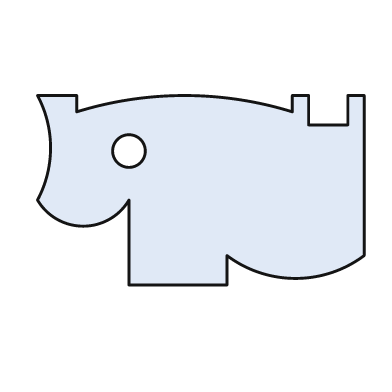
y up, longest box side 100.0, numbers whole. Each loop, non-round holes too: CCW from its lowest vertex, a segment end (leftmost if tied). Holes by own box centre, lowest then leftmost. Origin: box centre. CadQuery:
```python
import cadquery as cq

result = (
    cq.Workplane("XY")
    .moveTo(-22.0, -29.0)
    .lineTo(8.0, -29.0)
    .lineTo(8.0, -20.0)
    .threePointArc((29.0, -27.0), (50.0, -20.0))
    .lineTo(50.0, 29.0)
    .lineTo(45.0, 29.0)
    .lineTo(45.0, 20.0)
    .lineTo(33.0, 20.0)
    .lineTo(33.0, 29.0)
    .lineTo(28.0, 29.0)
    .lineTo(28.0, 24.0)
    .threePointArc((-5.0, 29.0), (-38.0, 24.0))
    .lineTo(-38.0, 29.0)
    .lineTo(-50.0, 29.0)
    .threePointArc((-46.0, 13.0), (-50.0, -3.0))
    .threePointArc((-36.0, -11.0), (-22.0, -3.0))
    .close()
    .moveTo(-22.0, 12.0)
    .circle(5.0)
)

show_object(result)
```